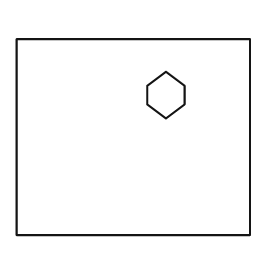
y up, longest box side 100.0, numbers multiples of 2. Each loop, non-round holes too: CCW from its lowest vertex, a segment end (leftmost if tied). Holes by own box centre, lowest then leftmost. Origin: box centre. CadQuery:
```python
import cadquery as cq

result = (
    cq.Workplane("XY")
    .moveTo(-50.0, -42.0)
    .lineTo(50.0, -42.0)
    .lineTo(50.0, 42.0)
    .lineTo(-50.0, 42.0)
    .close()
    .moveTo(14.0, 8.0)
    .lineTo(22.0, 14.0)
    .lineTo(22.0, 22.0)
    .lineTo(14.0, 28.0)
    .lineTo(6.0, 22.0)
    .lineTo(6.0, 14.0)
    .close()
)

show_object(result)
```